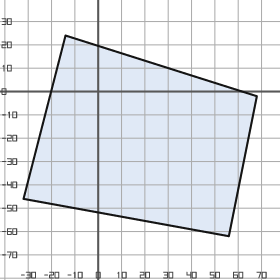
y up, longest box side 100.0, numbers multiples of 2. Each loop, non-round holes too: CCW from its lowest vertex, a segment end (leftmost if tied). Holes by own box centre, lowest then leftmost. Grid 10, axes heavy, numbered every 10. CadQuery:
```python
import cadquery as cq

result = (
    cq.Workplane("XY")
    .moveTo(56.0, -62.0)
    .lineTo(68.0, -2.0)
    .lineTo(-14.0, 24.0)
    .lineTo(-32.0, -46.0)
    .close()
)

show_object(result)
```